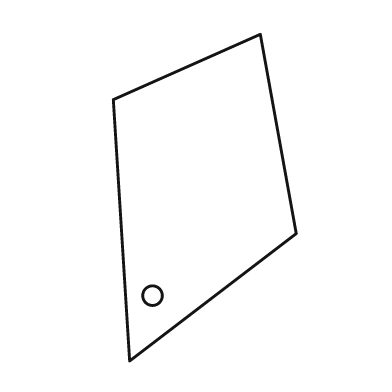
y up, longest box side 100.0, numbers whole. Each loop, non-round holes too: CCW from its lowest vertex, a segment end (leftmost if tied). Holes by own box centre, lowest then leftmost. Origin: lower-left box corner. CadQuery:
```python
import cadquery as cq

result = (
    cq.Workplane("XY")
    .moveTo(5.0, 0.0)
    .lineTo(56.0, 39.0)
    .lineTo(45.0, 100.0)
    .lineTo(0.0, 80.0)
    .close()
    .moveTo(12.0, 20.0)
    .circle(3.0)
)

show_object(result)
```